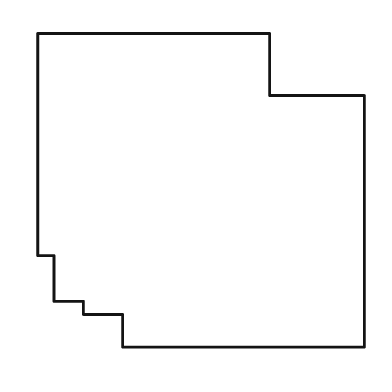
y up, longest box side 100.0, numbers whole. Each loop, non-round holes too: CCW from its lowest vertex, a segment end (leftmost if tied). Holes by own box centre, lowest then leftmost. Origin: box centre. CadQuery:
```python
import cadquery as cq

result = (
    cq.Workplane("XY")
    .moveTo(-24.0, -48.0)
    .lineTo(50.0, -48.0)
    .lineTo(50.0, 29.0)
    .lineTo(21.0, 29.0)
    .lineTo(21.0, 48.0)
    .lineTo(-50.0, 48.0)
    .lineTo(-50.0, -20.0)
    .lineTo(-45.0, -20.0)
    .lineTo(-45.0, -34.0)
    .lineTo(-36.0, -34.0)
    .lineTo(-36.0, -38.0)
    .lineTo(-24.0, -38.0)
    .close()
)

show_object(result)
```